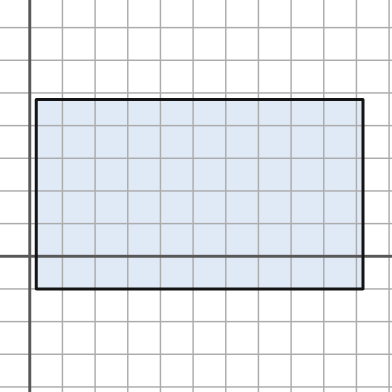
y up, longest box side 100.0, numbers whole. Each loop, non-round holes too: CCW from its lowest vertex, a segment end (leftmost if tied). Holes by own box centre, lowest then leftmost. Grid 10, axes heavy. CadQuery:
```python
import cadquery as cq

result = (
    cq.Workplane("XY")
    .moveTo(2.0, -10.0)
    .lineTo(102.0, -10.0)
    .lineTo(102.0, 48.0)
    .lineTo(2.0, 48.0)
    .close()
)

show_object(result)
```